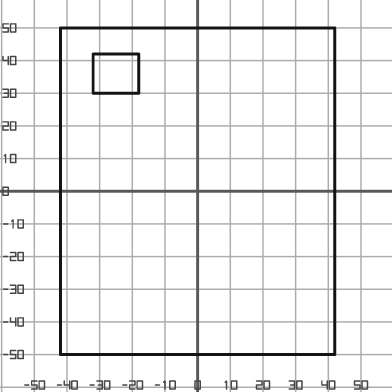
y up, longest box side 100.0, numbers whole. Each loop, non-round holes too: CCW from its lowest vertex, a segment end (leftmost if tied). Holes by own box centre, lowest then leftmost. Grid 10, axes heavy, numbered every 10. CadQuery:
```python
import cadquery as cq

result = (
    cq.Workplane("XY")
    .moveTo(-42.0, -50.0)
    .lineTo(42.0, -50.0)
    .lineTo(42.0, 50.0)
    .lineTo(-42.0, 50.0)
    .close()
    .moveTo(-32.0, 30.0)
    .lineTo(-18.0, 30.0)
    .lineTo(-18.0, 42.0)
    .lineTo(-32.0, 42.0)
    .close()
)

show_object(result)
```